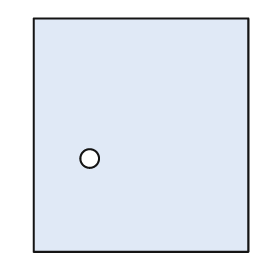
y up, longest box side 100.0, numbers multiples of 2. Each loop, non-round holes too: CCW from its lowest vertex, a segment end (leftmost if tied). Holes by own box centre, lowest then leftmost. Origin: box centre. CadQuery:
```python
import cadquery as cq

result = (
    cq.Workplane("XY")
    .moveTo(-46.0, -50.0)
    .lineTo(46.0, -50.0)
    .lineTo(46.0, 50.0)
    .lineTo(-46.0, 50.0)
    .close()
    .moveTo(-22.0, -10.0)
    .circle(4.0)
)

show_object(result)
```